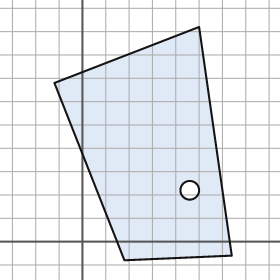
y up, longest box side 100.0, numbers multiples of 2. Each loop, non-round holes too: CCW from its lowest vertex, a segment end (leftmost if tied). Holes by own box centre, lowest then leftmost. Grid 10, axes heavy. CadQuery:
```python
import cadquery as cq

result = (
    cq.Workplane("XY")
    .moveTo(18.0, -8.0)
    .lineTo(64.0, -6.0)
    .lineTo(50.0, 92.0)
    .lineTo(-12.0, 68.0)
    .close()
    .moveTo(46.0, 22.0)
    .circle(4.0)
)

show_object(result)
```